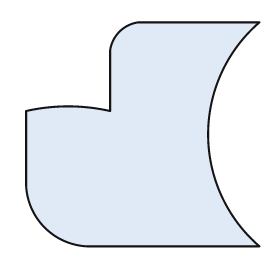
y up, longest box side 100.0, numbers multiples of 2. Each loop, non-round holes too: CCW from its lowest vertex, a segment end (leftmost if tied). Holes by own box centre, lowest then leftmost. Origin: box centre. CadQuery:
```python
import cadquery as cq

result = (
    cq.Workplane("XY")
    .moveTo(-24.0, -48.0)
    .lineTo(50.0, -48.0)
    .threePointArc((28.0, 0.0), (50.0, 48.0))
    .lineTo(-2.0, 48.0)
    .threePointArc((-10.0, 44.0), (-14.0, 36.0))
    .lineTo(-14.0, 10.0)
    .threePointArc((-32.0, 12.0), (-50.0, 10.0))
    .lineTo(-50.0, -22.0)
    .threePointArc((-42.0, -40.0), (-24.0, -48.0))
    .close()
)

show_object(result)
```